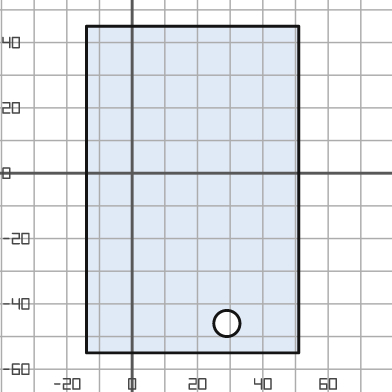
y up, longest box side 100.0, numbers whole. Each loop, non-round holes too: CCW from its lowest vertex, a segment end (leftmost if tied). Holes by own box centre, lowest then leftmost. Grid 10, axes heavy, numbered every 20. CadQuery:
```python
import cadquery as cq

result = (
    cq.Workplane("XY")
    .moveTo(-14.0, -55.0)
    .lineTo(51.0, -55.0)
    .lineTo(51.0, 45.0)
    .lineTo(-14.0, 45.0)
    .close()
    .moveTo(29.0, -46.0)
    .circle(4.0)
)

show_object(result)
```